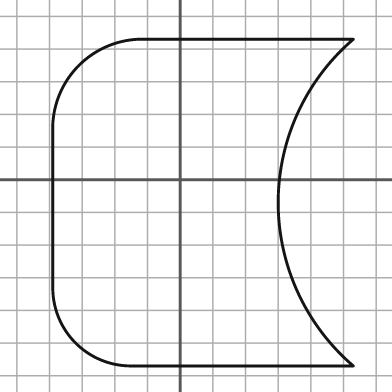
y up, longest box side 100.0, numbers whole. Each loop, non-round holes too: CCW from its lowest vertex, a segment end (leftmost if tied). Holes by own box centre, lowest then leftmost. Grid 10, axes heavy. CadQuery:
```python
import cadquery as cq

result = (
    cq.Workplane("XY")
    .moveTo(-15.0, -57.0)
    .lineTo(53.0, -57.0)
    .threePointArc((30.0, -7.0), (53.0, 43.0))
    .lineTo(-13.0, 43.0)
    .threePointArc((-31.0, 35.0), (-39.0, 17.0))
    .lineTo(-39.0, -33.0)
    .threePointArc((-32.0, -50.0), (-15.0, -57.0))
    .close()
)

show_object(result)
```